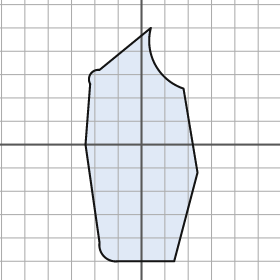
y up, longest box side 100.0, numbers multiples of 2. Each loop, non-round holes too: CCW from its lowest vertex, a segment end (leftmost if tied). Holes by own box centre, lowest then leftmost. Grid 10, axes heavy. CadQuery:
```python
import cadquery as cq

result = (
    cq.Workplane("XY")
    .moveTo(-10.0, -50.0)
    .lineTo(14.0, -50.0)
    .lineTo(24.0, -12.0)
    .lineTo(18.0, 24.0)
    .threePointArc((6.0, 34.0), (4.0, 50.0))
    .lineTo(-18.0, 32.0)
    .threePointArc((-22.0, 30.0), (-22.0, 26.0))
    .lineTo(-24.0, 0.0)
    .lineTo(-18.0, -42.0)
    .threePointArc((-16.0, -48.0), (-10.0, -50.0))
    .close()
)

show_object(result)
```